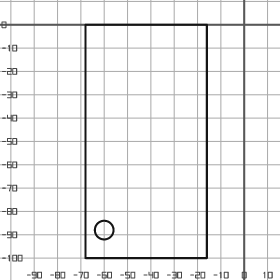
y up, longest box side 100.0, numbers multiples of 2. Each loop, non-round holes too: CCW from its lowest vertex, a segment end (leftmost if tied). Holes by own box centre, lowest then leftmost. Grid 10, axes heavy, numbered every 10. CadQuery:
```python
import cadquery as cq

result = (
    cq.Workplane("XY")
    .moveTo(-68.0, -100.0)
    .lineTo(-16.0, -100.0)
    .lineTo(-16.0, 0.0)
    .lineTo(-68.0, 0.0)
    .close()
    .moveTo(-60.0, -88.0)
    .circle(4.0)
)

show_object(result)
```